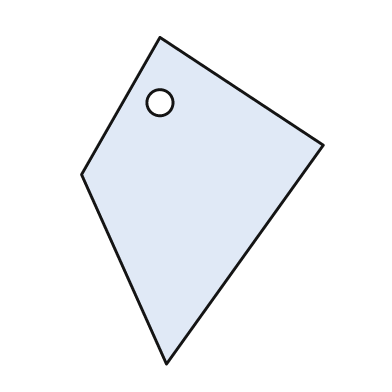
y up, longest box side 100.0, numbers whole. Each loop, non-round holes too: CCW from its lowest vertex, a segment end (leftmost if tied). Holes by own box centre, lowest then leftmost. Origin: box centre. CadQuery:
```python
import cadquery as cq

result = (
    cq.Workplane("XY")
    .moveTo(-11.0, -50.0)
    .lineTo(37.0, 17.0)
    .lineTo(-13.0, 50.0)
    .lineTo(-37.0, 8.0)
    .close()
    .moveTo(-13.0, 30.0)
    .circle(4.0)
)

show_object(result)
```